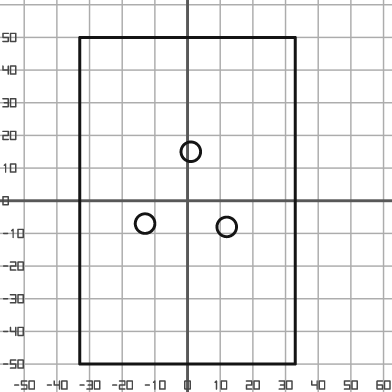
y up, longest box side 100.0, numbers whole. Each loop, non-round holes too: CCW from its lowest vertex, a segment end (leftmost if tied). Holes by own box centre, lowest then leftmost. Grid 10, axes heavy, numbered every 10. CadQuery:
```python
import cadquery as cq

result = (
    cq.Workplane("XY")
    .moveTo(-33.0, -50.0)
    .lineTo(33.0, -50.0)
    .lineTo(33.0, 50.0)
    .lineTo(-33.0, 50.0)
    .close()
    .moveTo(12.0, -8.0)
    .circle(3.0)
    .moveTo(-13.0, -7.0)
    .circle(3.0)
    .moveTo(1.0, 15.0)
    .circle(3.0)
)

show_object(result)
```